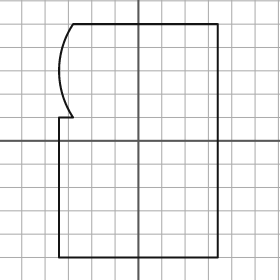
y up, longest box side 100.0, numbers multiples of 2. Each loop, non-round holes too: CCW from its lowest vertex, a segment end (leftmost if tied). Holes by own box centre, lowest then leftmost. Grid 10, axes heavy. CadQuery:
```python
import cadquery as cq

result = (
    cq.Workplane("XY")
    .moveTo(-34.0, -50.0)
    .lineTo(34.0, -50.0)
    .lineTo(34.0, 50.0)
    .lineTo(-28.0, 50.0)
    .threePointArc((-34.0, 30.0), (-28.0, 10.0))
    .lineTo(-34.0, 10.0)
    .close()
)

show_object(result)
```